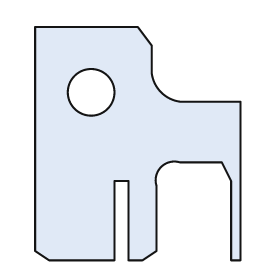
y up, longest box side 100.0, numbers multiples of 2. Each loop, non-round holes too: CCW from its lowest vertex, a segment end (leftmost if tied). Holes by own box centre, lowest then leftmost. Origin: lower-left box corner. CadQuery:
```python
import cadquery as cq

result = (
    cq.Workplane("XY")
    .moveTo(6.0, 0.0)
    .lineTo(34.0, 0.0)
    .lineTo(34.0, 34.0)
    .lineTo(40.0, 34.0)
    .lineTo(40.0, 0.0)
    .lineTo(46.0, 0.0)
    .lineTo(52.0, 4.0)
    .lineTo(52.0, 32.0)
    .threePointArc((54.0, 40.0), (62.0, 42.0))
    .lineTo(80.0, 42.0)
    .lineTo(84.0, 34.0)
    .lineTo(84.0, 0.0)
    .lineTo(88.0, 0.0)
    .lineTo(88.0, 68.0)
    .lineTo(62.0, 68.0)
    .threePointArc((54.0, 72.0), (50.0, 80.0))
    .lineTo(50.0, 92.0)
    .lineTo(44.0, 100.0)
    .lineTo(0.0, 100.0)
    .lineTo(0.0, 4.0)
    .close()
    .moveTo(24.0, 72.0)
    .circle(10.0)
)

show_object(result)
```